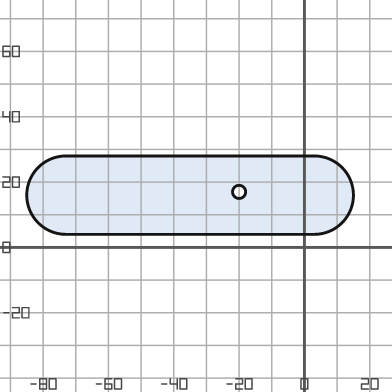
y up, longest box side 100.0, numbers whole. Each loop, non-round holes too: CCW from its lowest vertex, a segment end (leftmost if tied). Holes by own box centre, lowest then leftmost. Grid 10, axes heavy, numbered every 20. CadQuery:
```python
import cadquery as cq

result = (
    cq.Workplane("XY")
    .moveTo(-73.0, 4.0)
    .lineTo(3.0, 4.0)
    .threePointArc((15.0, 16.0), (3.0, 28.0))
    .lineTo(-73.0, 28.0)
    .threePointArc((-85.0, 16.0), (-73.0, 4.0))
    .close()
    .moveTo(-20.0, 17.0)
    .circle(2.0)
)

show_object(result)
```